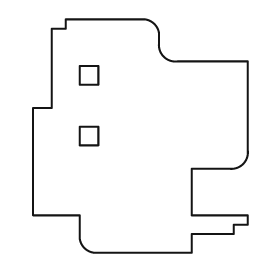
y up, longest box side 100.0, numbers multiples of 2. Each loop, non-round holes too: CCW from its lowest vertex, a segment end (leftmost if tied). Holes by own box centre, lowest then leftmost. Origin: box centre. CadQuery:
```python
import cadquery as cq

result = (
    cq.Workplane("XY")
    .moveTo(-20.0, -50.0)
    .lineTo(22.0, -50.0)
    .lineTo(22.0, -42.0)
    .lineTo(40.0, -42.0)
    .lineTo(40.0, -38.0)
    .lineTo(46.0, -38.0)
    .lineTo(46.0, -34.0)
    .lineTo(22.0, -34.0)
    .lineTo(22.0, -14.0)
    .lineTo(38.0, -14.0)
    .threePointArc((44.0, -12.0), (46.0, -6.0))
    .lineTo(46.0, 32.0)
    .lineTo(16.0, 32.0)
    .threePointArc((10.0, 34.0), (8.0, 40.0))
    .lineTo(8.0, 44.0)
    .threePointArc((6.0, 48.0), (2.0, 50.0))
    .lineTo(-32.0, 50.0)
    .lineTo(-32.0, 46.0)
    .lineTo(-38.0, 46.0)
    .lineTo(-38.0, 12.0)
    .lineTo(-46.0, 12.0)
    .lineTo(-46.0, -34.0)
    .lineTo(-26.0, -34.0)
    .lineTo(-26.0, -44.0)
    .threePointArc((-24.0, -48.0), (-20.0, -50.0))
    .close()
    .moveTo(-26.0, -4.0)
    .lineTo(-18.0, -4.0)
    .lineTo(-18.0, 4.0)
    .lineTo(-26.0, 4.0)
    .close()
    .moveTo(-26.0, 22.0)
    .lineTo(-18.0, 22.0)
    .lineTo(-18.0, 30.0)
    .lineTo(-26.0, 30.0)
    .close()
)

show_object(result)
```